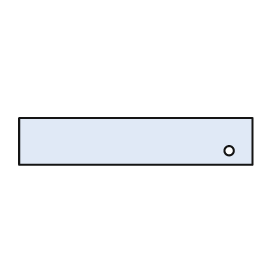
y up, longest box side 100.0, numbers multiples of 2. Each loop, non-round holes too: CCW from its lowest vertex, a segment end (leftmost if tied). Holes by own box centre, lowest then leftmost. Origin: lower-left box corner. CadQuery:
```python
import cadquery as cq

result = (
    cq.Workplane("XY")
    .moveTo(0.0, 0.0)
    .lineTo(100.0, 0.0)
    .lineTo(100.0, 20.0)
    .lineTo(0.0, 20.0)
    .close()
    .moveTo(90.0, 6.0)
    .circle(2.0)
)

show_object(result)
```